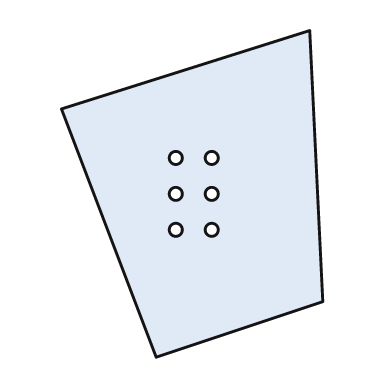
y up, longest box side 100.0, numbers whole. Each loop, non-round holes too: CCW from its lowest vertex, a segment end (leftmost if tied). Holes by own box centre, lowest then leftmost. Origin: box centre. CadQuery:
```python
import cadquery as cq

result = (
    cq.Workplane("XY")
    .moveTo(-11.0, -50.0)
    .lineTo(40.0, -33.0)
    .lineTo(36.0, 50.0)
    .lineTo(-40.0, 26.0)
    .close()
    .moveTo(-5.0, -11.0)
    .circle(2.0)
    .moveTo(6.0, -11.0)
    .circle(2.0)
    .moveTo(-5.0, 0.0)
    .circle(2.0)
    .moveTo(6.0, 0.0)
    .circle(2.0)
    .moveTo(-5.0, 11.0)
    .circle(2.0)
    .moveTo(6.0, 11.0)
    .circle(2.0)
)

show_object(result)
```